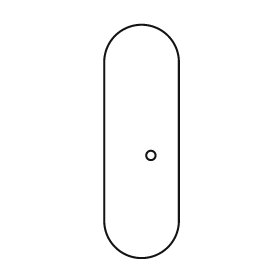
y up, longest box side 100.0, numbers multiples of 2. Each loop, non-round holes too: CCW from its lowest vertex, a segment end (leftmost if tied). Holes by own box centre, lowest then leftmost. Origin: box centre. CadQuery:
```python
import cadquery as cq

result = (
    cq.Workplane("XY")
    .moveTo(-16.0, -34.0)
    .threePointArc((0.0, -50.0), (16.0, -34.0))
    .lineTo(16.0, 34.0)
    .threePointArc((0.0, 50.0), (-16.0, 34.0))
    .close()
    .moveTo(4.0, -6.0)
    .circle(2.0)
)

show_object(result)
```